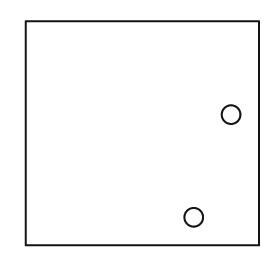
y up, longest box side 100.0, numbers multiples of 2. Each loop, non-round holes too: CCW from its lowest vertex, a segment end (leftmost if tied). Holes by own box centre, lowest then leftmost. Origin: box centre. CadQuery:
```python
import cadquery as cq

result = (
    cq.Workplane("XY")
    .moveTo(-50.0, -48.0)
    .lineTo(50.0, -48.0)
    .lineTo(50.0, 48.0)
    .lineTo(-50.0, 48.0)
    .close()
    .moveTo(22.0, -36.0)
    .circle(4.0)
    .moveTo(38.0, 8.0)
    .circle(4.0)
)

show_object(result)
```